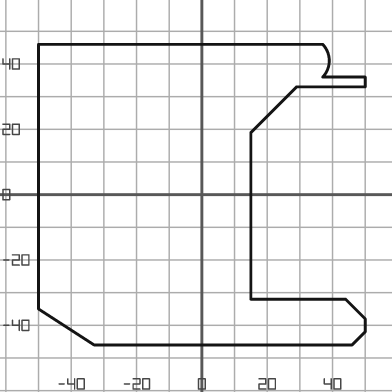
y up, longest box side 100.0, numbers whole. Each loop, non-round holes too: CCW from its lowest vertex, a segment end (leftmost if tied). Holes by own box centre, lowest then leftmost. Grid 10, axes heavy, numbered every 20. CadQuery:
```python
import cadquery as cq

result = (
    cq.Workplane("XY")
    .moveTo(-33.0, -46.0)
    .lineTo(46.0, -46.0)
    .lineTo(50.0, -42.0)
    .lineTo(50.0, -38.0)
    .lineTo(44.0, -32.0)
    .lineTo(15.0, -32.0)
    .lineTo(15.0, 19.0)
    .lineTo(29.0, 33.0)
    .lineTo(50.0, 33.0)
    .lineTo(50.0, 36.0)
    .lineTo(37.0, 36.0)
    .threePointArc((39.0, 41.0), (37.0, 46.0))
    .lineTo(-50.0, 46.0)
    .lineTo(-50.0, -35.0)
    .close()
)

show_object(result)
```